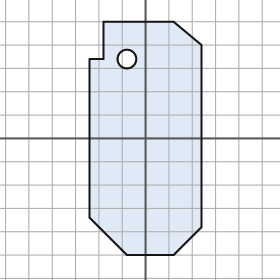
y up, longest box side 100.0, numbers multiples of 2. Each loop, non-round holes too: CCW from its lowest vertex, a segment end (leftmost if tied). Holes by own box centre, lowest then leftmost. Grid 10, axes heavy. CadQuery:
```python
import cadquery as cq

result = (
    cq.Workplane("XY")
    .moveTo(-8.0, -50.0)
    .lineTo(12.0, -50.0)
    .lineTo(24.0, -38.0)
    .lineTo(24.0, 40.0)
    .lineTo(12.0, 50.0)
    .lineTo(-18.0, 50.0)
    .lineTo(-18.0, 34.0)
    .lineTo(-24.0, 34.0)
    .lineTo(-24.0, -34.0)
    .close()
    .moveTo(-8.0, 34.0)
    .circle(4.0)
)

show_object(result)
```